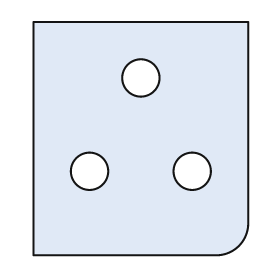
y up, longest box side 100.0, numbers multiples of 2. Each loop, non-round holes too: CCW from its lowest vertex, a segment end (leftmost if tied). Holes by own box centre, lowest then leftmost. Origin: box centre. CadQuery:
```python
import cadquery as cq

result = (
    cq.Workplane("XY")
    .moveTo(-46.0, -50.0)
    .lineTo(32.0, -50.0)
    .threePointArc((42.0, -46.0), (46.0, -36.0))
    .lineTo(46.0, 50.0)
    .lineTo(-46.0, 50.0)
    .close()
    .moveTo(-22.0, -14.0)
    .circle(8.0)
    .moveTo(22.0, -14.0)
    .circle(8.0)
    .moveTo(0.0, 26.0)
    .circle(8.0)
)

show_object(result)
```